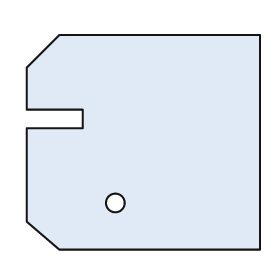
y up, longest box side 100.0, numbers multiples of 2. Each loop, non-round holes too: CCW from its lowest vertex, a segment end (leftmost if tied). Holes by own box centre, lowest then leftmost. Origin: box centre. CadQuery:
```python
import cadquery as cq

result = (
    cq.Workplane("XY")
    .moveTo(-36.0, -46.0)
    .lineTo(50.0, -46.0)
    .lineTo(50.0, 46.0)
    .lineTo(-36.0, 46.0)
    .lineTo(-50.0, 32.0)
    .lineTo(-50.0, 14.0)
    .lineTo(-26.0, 14.0)
    .lineTo(-26.0, 6.0)
    .lineTo(-50.0, 6.0)
    .lineTo(-50.0, -34.0)
    .close()
    .moveTo(-12.0, -26.0)
    .circle(4.0)
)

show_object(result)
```